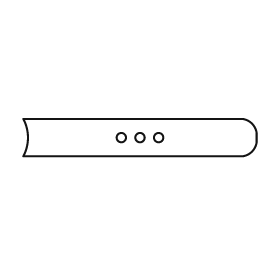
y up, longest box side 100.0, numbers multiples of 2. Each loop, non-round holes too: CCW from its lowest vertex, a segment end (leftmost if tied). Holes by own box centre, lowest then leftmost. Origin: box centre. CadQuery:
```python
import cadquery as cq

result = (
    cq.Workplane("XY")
    .moveTo(-50.0, -8.0)
    .lineTo(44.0, -8.0)
    .threePointArc((48.0, -6.0), (50.0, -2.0))
    .lineTo(50.0, 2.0)
    .threePointArc((48.0, 6.0), (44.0, 8.0))
    .lineTo(-50.0, 8.0)
    .threePointArc((-48.0, 0.0), (-50.0, -8.0))
    .close()
    .moveTo(-8.0, 0.0)
    .circle(2.0)
    .moveTo(0.0, 0.0)
    .circle(2.0)
    .moveTo(8.0, 0.0)
    .circle(2.0)
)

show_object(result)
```